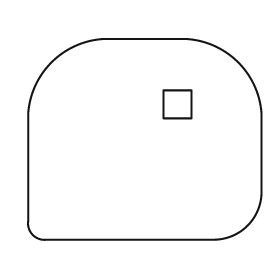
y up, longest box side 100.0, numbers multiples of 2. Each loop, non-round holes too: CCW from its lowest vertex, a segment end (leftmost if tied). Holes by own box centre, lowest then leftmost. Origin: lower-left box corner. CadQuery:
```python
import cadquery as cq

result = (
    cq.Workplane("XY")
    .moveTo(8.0, 0.0)
    .lineTo(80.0, 0.0)
    .threePointArc((94.0, 6.0), (100.0, 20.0))
    .lineTo(100.0, 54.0)
    .threePointArc((90.0, 76.0), (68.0, 86.0))
    .lineTo(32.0, 86.0)
    .threePointArc((10.0, 76.0), (0.0, 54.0))
    .lineTo(0.0, 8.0)
    .threePointArc((2.0, 2.0), (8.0, 0.0))
    .close()
    .moveTo(58.0, 52.0)
    .lineTo(70.0, 52.0)
    .lineTo(70.0, 64.0)
    .lineTo(58.0, 64.0)
    .close()
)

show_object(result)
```